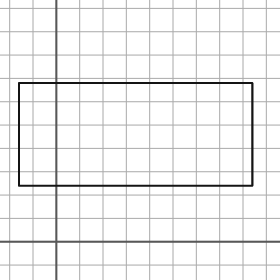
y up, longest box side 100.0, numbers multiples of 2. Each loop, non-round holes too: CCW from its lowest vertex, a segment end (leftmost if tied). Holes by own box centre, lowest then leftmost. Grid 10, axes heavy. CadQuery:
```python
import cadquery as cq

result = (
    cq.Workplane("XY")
    .moveTo(-16.0, 24.0)
    .lineTo(84.0, 24.0)
    .lineTo(84.0, 68.0)
    .lineTo(-16.0, 68.0)
    .close()
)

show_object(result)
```